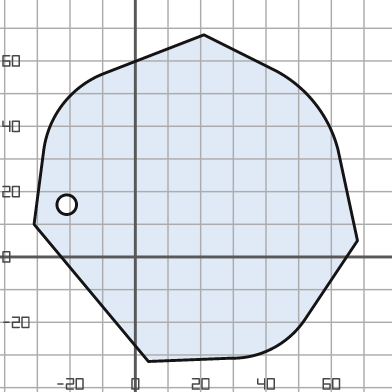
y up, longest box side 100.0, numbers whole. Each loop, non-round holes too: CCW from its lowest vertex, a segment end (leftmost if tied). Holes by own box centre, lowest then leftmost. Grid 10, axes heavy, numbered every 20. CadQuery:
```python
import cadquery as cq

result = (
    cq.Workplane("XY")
    .moveTo(4.0, -32.0)
    .lineTo(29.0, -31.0)
    .threePointArc((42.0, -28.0), (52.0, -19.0))
    .lineTo(68.0, 5.0)
    .lineTo(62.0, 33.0)
    .threePointArc((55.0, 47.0), (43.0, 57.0))
    .lineTo(21.0, 68.0)
    .lineTo(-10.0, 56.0)
    .threePointArc((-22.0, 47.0), (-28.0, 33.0))
    .lineTo(-31.0, 10.0)
    .close()
    .moveTo(-21.0, 16.0)
    .circle(3.0)
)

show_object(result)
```